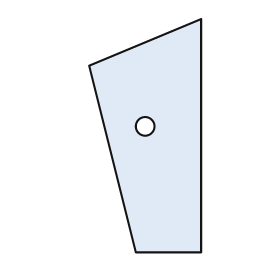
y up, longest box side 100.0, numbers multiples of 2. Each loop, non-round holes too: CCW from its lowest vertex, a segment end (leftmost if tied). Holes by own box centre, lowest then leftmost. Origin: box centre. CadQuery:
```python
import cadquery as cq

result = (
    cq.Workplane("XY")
    .moveTo(-4.0, -50.0)
    .lineTo(24.0, -50.0)
    .lineTo(24.0, 50.0)
    .lineTo(-24.0, 30.0)
    .close()
    .moveTo(0.0, 4.0)
    .circle(4.0)
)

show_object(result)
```